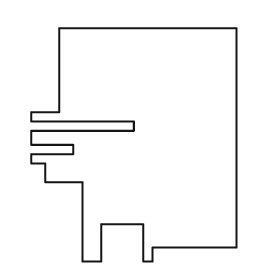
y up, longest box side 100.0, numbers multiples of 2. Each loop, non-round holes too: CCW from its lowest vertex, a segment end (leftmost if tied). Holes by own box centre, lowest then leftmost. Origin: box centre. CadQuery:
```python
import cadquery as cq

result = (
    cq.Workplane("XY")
    .moveTo(-22.0, -50.0)
    .lineTo(-14.0, -50.0)
    .lineTo(-14.0, -34.0)
    .lineTo(4.0, -34.0)
    .lineTo(4.0, -50.0)
    .lineTo(8.0, -50.0)
    .lineTo(8.0, -44.0)
    .lineTo(44.0, -44.0)
    .lineTo(44.0, 50.0)
    .lineTo(-32.0, 50.0)
    .lineTo(-32.0, 14.0)
    .lineTo(-44.0, 14.0)
    .lineTo(-44.0, 10.0)
    .lineTo(0.0, 10.0)
    .lineTo(0.0, 6.0)
    .lineTo(-44.0, 6.0)
    .lineTo(-44.0, 0.0)
    .lineTo(-26.0, 0.0)
    .lineTo(-26.0, -4.0)
    .lineTo(-44.0, -4.0)
    .lineTo(-44.0, -8.0)
    .lineTo(-38.0, -8.0)
    .lineTo(-38.0, -16.0)
    .lineTo(-22.0, -16.0)
    .close()
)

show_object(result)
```